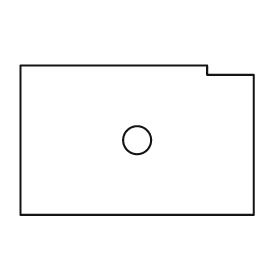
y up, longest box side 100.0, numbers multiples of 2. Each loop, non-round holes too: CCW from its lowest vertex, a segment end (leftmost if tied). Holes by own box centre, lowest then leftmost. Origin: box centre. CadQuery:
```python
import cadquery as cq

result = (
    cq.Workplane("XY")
    .moveTo(-50.0, -32.0)
    .lineTo(50.0, -32.0)
    .lineTo(50.0, 28.0)
    .lineTo(30.0, 28.0)
    .lineTo(30.0, 32.0)
    .lineTo(-50.0, 32.0)
    .close()
    .moveTo(0.0, 0.0)
    .circle(6.0)
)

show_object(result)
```